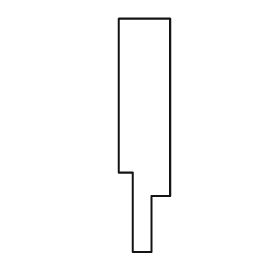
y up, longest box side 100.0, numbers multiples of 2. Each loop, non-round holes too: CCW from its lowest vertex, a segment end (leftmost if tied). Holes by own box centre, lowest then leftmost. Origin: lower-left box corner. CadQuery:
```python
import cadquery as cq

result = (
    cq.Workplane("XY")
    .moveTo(6.0, 0.0)
    .lineTo(14.0, 0.0)
    .lineTo(14.0, 24.0)
    .lineTo(22.0, 24.0)
    .lineTo(22.0, 100.0)
    .lineTo(0.0, 100.0)
    .lineTo(0.0, 34.0)
    .lineTo(6.0, 34.0)
    .close()
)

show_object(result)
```